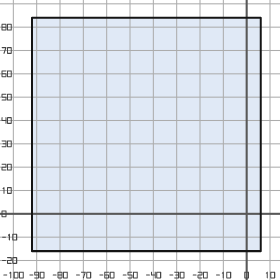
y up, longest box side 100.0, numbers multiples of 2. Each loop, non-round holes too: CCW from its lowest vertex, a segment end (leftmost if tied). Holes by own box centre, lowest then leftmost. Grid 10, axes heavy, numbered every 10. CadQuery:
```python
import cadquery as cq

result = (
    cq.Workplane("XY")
    .moveTo(-92.0, -16.0)
    .lineTo(6.0, -16.0)
    .lineTo(6.0, 84.0)
    .lineTo(-92.0, 84.0)
    .close()
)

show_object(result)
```